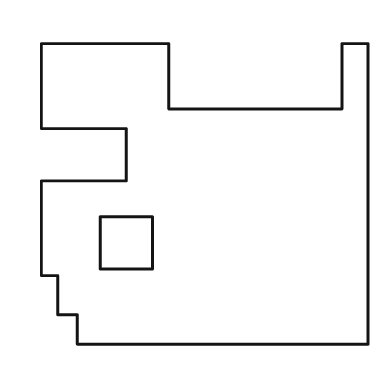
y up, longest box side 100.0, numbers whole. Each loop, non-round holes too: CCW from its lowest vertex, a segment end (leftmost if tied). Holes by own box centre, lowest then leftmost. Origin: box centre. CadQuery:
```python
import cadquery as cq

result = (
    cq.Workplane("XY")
    .moveTo(-39.0, -46.0)
    .lineTo(50.0, -46.0)
    .lineTo(50.0, 46.0)
    .lineTo(42.0, 46.0)
    .lineTo(42.0, 26.0)
    .lineTo(-11.0, 26.0)
    .lineTo(-11.0, 46.0)
    .lineTo(-50.0, 46.0)
    .lineTo(-50.0, 20.0)
    .lineTo(-24.0, 20.0)
    .lineTo(-24.0, 4.0)
    .lineTo(-50.0, 4.0)
    .lineTo(-50.0, -25.0)
    .lineTo(-45.0, -25.0)
    .lineTo(-45.0, -37.0)
    .lineTo(-39.0, -37.0)
    .close()
    .moveTo(-32.0, -23.0)
    .lineTo(-16.0, -23.0)
    .lineTo(-16.0, -7.0)
    .lineTo(-32.0, -7.0)
    .close()
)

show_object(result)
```